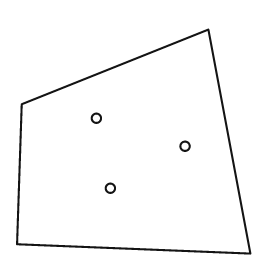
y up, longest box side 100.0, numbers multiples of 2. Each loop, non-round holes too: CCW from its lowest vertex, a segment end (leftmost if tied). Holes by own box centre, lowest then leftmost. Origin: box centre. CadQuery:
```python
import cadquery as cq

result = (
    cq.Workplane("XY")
    .moveTo(50.0, -48.0)
    .lineTo(32.0, 48.0)
    .lineTo(-48.0, 16.0)
    .lineTo(-50.0, -44.0)
    .close()
    .moveTo(-10.0, -20.0)
    .circle(2.0)
    .moveTo(22.0, -2.0)
    .circle(2.0)
    .moveTo(-16.0, 10.0)
    .circle(2.0)
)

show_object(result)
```